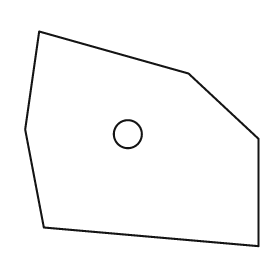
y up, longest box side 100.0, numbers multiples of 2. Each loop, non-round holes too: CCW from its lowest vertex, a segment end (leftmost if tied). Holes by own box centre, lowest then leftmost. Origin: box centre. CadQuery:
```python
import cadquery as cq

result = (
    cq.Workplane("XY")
    .moveTo(50.0, -46.0)
    .lineTo(50.0, 0.0)
    .lineTo(20.0, 28.0)
    .lineTo(-44.0, 46.0)
    .lineTo(-50.0, 4.0)
    .lineTo(-42.0, -38.0)
    .close()
    .moveTo(-6.0, 2.0)
    .circle(6.0)
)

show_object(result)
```